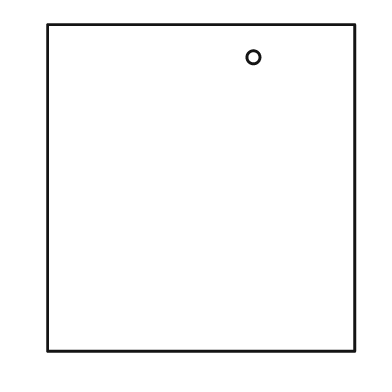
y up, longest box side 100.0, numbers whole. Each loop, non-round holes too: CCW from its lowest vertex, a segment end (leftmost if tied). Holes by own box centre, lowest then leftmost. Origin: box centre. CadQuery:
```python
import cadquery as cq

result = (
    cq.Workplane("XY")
    .moveTo(-47.0, -50.0)
    .lineTo(47.0, -50.0)
    .lineTo(47.0, 50.0)
    .lineTo(-47.0, 50.0)
    .close()
    .moveTo(16.0, 40.0)
    .circle(2.0)
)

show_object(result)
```